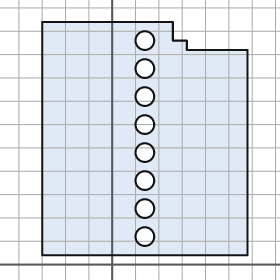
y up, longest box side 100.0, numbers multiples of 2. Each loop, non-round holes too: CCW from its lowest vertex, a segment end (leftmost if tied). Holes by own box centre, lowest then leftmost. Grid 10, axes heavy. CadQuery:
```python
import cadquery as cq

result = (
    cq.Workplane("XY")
    .moveTo(-30.0, 4.0)
    .lineTo(58.0, 4.0)
    .lineTo(58.0, 92.0)
    .lineTo(32.0, 92.0)
    .lineTo(32.0, 96.0)
    .lineTo(26.0, 96.0)
    .lineTo(26.0, 104.0)
    .lineTo(-30.0, 104.0)
    .close()
    .moveTo(14.0, 12.0)
    .circle(4.0)
    .moveTo(14.0, 24.0)
    .circle(4.0)
    .moveTo(14.0, 36.0)
    .circle(4.0)
    .moveTo(14.0, 48.0)
    .circle(4.0)
    .moveTo(14.0, 60.0)
    .circle(4.0)
    .moveTo(14.0, 72.0)
    .circle(4.0)
    .moveTo(14.0, 84.0)
    .circle(4.0)
    .moveTo(14.0, 96.0)
    .circle(4.0)
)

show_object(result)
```